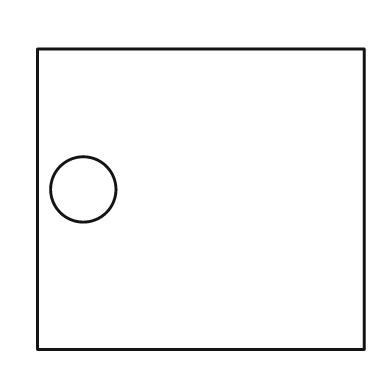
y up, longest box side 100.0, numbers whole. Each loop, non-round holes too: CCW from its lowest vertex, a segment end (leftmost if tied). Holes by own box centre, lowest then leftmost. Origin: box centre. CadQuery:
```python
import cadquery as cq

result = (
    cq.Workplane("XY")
    .moveTo(-50.0, -46.0)
    .lineTo(50.0, -46.0)
    .lineTo(50.0, 46.0)
    .lineTo(-50.0, 46.0)
    .close()
    .moveTo(-36.0, 3.0)
    .circle(10.0)
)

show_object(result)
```